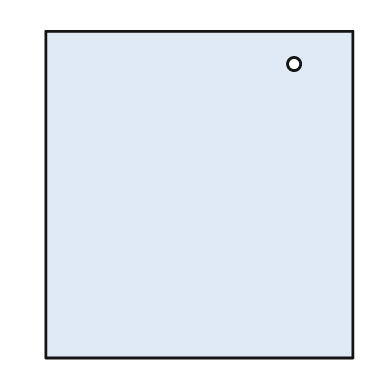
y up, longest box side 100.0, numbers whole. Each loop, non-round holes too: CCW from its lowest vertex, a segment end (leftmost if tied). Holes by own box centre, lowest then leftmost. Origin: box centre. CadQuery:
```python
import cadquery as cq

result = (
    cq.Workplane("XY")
    .moveTo(-47.0, -50.0)
    .lineTo(47.0, -50.0)
    .lineTo(47.0, 50.0)
    .lineTo(-47.0, 50.0)
    .close()
    .moveTo(29.0, 40.0)
    .circle(2.0)
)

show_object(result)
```